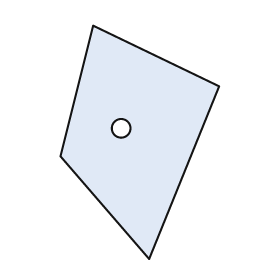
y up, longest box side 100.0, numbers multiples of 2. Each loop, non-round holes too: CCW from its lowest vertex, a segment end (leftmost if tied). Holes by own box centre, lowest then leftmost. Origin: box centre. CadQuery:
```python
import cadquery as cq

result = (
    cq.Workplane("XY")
    .moveTo(4.0, -50.0)
    .lineTo(34.0, 24.0)
    .lineTo(-20.0, 50.0)
    .lineTo(-34.0, -6.0)
    .close()
    .moveTo(-8.0, 6.0)
    .circle(4.0)
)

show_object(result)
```